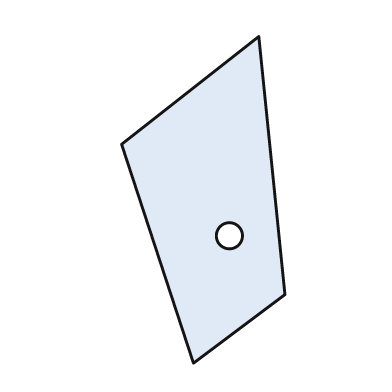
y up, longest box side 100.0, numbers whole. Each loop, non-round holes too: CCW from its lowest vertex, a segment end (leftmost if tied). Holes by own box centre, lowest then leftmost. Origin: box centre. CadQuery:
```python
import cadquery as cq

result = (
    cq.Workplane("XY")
    .moveTo(-3.0, -50.0)
    .lineTo(25.0, -29.0)
    .lineTo(17.0, 50.0)
    .lineTo(-25.0, 17.0)
    .close()
    .moveTo(8.0, -11.0)
    .circle(4.0)
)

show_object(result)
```